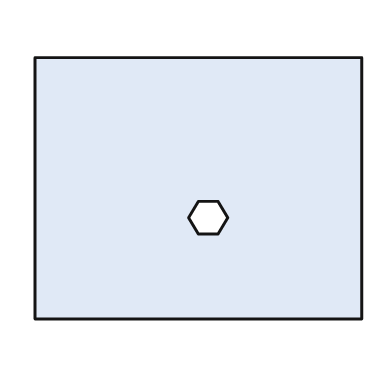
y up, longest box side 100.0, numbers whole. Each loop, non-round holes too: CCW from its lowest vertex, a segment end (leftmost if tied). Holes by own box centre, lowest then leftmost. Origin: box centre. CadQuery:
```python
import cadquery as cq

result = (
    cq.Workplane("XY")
    .moveTo(-50.0, -40.0)
    .lineTo(50.0, -40.0)
    .lineTo(50.0, 40.0)
    .lineTo(-50.0, 40.0)
    .close()
    .moveTo(0.0, -14.0)
    .lineTo(6.0, -14.0)
    .lineTo(9.0, -9.0)
    .lineTo(6.0, -4.0)
    .lineTo(0.0, -4.0)
    .lineTo(-3.0, -9.0)
    .close()
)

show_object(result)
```